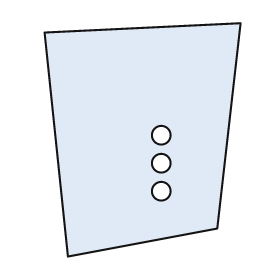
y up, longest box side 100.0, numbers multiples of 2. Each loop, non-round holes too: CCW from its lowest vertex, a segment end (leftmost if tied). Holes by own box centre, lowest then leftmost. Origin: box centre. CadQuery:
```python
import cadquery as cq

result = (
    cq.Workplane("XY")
    .moveTo(-32.0, -50.0)
    .lineTo(32.0, -38.0)
    .lineTo(42.0, 50.0)
    .lineTo(-42.0, 46.0)
    .close()
    .moveTo(8.0, -22.0)
    .circle(4.0)
    .moveTo(8.0, -10.0)
    .circle(4.0)
    .moveTo(8.0, 2.0)
    .circle(4.0)
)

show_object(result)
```